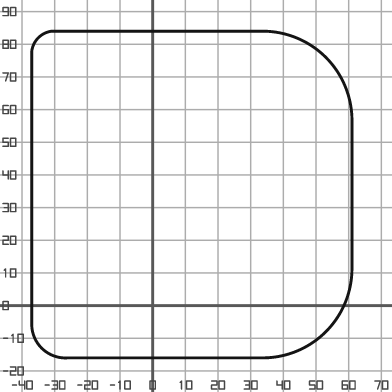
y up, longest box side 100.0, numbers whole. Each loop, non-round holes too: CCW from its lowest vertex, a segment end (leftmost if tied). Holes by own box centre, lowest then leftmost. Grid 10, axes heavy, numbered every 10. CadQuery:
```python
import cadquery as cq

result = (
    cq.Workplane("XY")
    .moveTo(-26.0, -16.0)
    .lineTo(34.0, -16.0)
    .threePointArc((53.0, -8.0), (61.0, 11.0))
    .lineTo(61.0, 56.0)
    .threePointArc((53.0, 76.0), (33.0, 84.0))
    .lineTo(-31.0, 84.0)
    .threePointArc((-35.0, 82.0), (-37.0, 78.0))
    .lineTo(-37.0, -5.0)
    .threePointArc((-34.0, -13.0), (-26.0, -16.0))
    .close()
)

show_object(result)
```